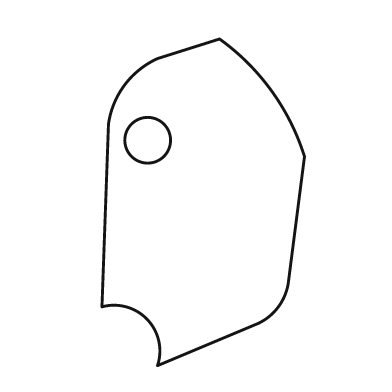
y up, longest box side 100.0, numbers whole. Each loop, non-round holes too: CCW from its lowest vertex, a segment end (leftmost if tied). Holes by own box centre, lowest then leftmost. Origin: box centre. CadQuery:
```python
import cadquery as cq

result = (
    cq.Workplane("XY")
    .moveTo(-14.0, -50.0)
    .lineTo(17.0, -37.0)
    .threePointArc((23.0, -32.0), (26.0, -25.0))
    .lineTo(31.0, 14.0)
    .threePointArc((21.0, 34.0), (5.0, 50.0))
    .lineTo(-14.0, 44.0)
    .threePointArc((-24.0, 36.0), (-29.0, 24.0))
    .lineTo(-31.0, -32.0)
    .threePointArc((-17.0, -36.0), (-14.0, -50.0))
    .close()
    .moveTo(-17.0, 19.0)
    .circle(7.0)
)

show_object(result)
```